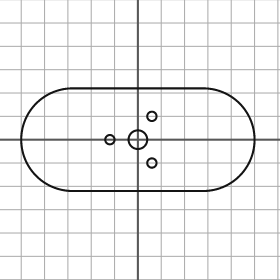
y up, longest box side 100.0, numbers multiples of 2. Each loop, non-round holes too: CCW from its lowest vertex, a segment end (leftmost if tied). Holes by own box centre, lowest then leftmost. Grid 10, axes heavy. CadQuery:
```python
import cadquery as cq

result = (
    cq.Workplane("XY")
    .moveTo(-28.0, -22.0)
    .lineTo(28.0, -22.0)
    .threePointArc((50.0, 0.0), (28.0, 22.0))
    .lineTo(-28.0, 22.0)
    .threePointArc((-50.0, 0.0), (-28.0, -22.0))
    .close()
    .moveTo(6.0, -10.0)
    .circle(2.0)
    .moveTo(-12.0, 0.0)
    .circle(2.0)
    .moveTo(0.0, 0.0)
    .circle(4.0)
    .moveTo(6.0, 10.0)
    .circle(2.0)
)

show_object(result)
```